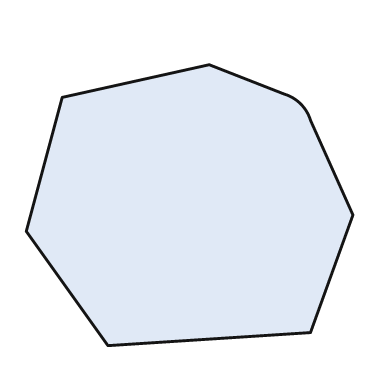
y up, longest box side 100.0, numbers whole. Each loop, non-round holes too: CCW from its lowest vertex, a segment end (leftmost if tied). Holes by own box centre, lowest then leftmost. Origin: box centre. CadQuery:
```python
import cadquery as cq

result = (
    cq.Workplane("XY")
    .moveTo(-25.0, -43.0)
    .lineTo(37.0, -39.0)
    .lineTo(50.0, -3.0)
    .lineTo(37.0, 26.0)
    .threePointArc((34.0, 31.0), (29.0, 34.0))
    .lineTo(6.0, 43.0)
    .lineTo(-39.0, 33.0)
    .lineTo(-50.0, -8.0)
    .close()
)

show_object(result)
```